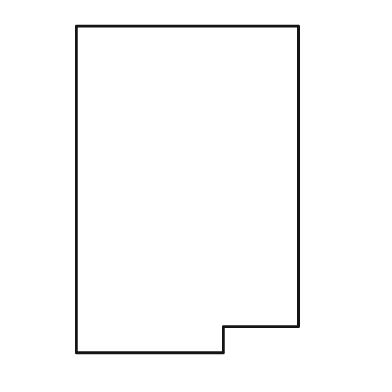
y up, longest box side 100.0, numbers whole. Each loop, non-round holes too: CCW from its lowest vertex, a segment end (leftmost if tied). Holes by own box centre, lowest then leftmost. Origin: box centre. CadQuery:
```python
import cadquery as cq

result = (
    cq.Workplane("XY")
    .moveTo(-34.0, -50.0)
    .lineTo(11.0, -50.0)
    .lineTo(11.0, -42.0)
    .lineTo(34.0, -42.0)
    .lineTo(34.0, 50.0)
    .lineTo(-34.0, 50.0)
    .close()
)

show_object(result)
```